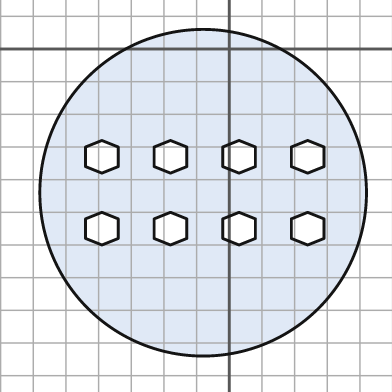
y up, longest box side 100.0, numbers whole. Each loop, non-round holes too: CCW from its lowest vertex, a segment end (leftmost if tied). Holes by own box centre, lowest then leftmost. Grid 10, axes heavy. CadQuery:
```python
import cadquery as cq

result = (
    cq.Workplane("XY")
    .moveTo(-8.0, -44.0)
    .circle(50.0)
    .moveTo(-39.0, -60.0)
    .lineTo(-34.0, -58.0)
    .lineTo(-34.0, -52.0)
    .lineTo(-39.0, -50.0)
    .lineTo(-44.0, -52.0)
    .lineTo(-44.0, -58.0)
    .close()
    .moveTo(-18.0, -60.0)
    .lineTo(-13.0, -58.0)
    .lineTo(-13.0, -52.0)
    .lineTo(-18.0, -50.0)
    .lineTo(-23.0, -52.0)
    .lineTo(-23.0, -58.0)
    .close()
    .moveTo(3.0, -60.0)
    .lineTo(8.0, -58.0)
    .lineTo(8.0, -52.0)
    .lineTo(3.0, -50.0)
    .lineTo(-2.0, -52.0)
    .lineTo(-2.0, -58.0)
    .close()
    .moveTo(24.0, -60.0)
    .lineTo(29.0, -58.0)
    .lineTo(29.0, -52.0)
    .lineTo(24.0, -50.0)
    .lineTo(19.0, -52.0)
    .lineTo(19.0, -58.0)
    .close()
    .moveTo(-39.0, -38.0)
    .lineTo(-34.0, -36.0)
    .lineTo(-34.0, -30.0)
    .lineTo(-39.0, -28.0)
    .lineTo(-44.0, -30.0)
    .lineTo(-44.0, -36.0)
    .close()
    .moveTo(-18.0, -38.0)
    .lineTo(-13.0, -36.0)
    .lineTo(-13.0, -30.0)
    .lineTo(-18.0, -28.0)
    .lineTo(-23.0, -30.0)
    .lineTo(-23.0, -36.0)
    .close()
    .moveTo(3.0, -38.0)
    .lineTo(8.0, -36.0)
    .lineTo(8.0, -30.0)
    .lineTo(3.0, -28.0)
    .lineTo(-2.0, -30.0)
    .lineTo(-2.0, -36.0)
    .close()
    .moveTo(24.0, -38.0)
    .lineTo(29.0, -36.0)
    .lineTo(29.0, -30.0)
    .lineTo(24.0, -28.0)
    .lineTo(19.0, -30.0)
    .lineTo(19.0, -36.0)
    .close()
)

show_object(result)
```